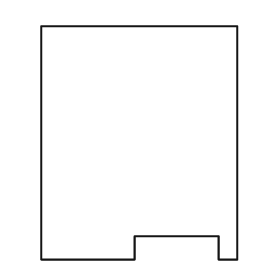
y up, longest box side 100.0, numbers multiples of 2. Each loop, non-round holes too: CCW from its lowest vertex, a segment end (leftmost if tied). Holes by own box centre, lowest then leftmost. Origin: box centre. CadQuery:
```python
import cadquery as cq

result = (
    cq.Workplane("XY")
    .moveTo(-42.0, -50.0)
    .lineTo(-2.0, -50.0)
    .lineTo(-2.0, -40.0)
    .lineTo(34.0, -40.0)
    .lineTo(34.0, -50.0)
    .lineTo(42.0, -50.0)
    .lineTo(42.0, 50.0)
    .lineTo(-42.0, 50.0)
    .close()
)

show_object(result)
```